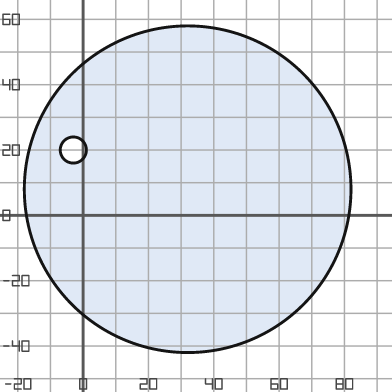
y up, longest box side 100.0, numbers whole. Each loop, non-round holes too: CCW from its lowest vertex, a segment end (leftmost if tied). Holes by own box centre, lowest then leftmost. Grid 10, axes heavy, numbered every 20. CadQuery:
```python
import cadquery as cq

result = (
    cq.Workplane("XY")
    .moveTo(32.0, 8.0)
    .circle(50.0)
    .moveTo(-3.0, 20.0)
    .circle(4.0)
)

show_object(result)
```